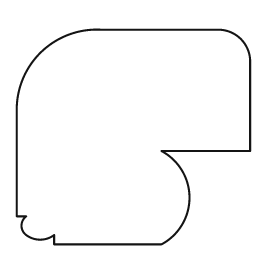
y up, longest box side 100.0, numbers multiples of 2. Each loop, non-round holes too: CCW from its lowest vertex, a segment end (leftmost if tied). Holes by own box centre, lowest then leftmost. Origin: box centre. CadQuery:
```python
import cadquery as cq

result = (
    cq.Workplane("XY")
    .moveTo(-34.0, -46.0)
    .lineTo(12.0, -46.0)
    .threePointArc((24.0, -26.0), (12.0, -6.0))
    .lineTo(50.0, -6.0)
    .lineTo(50.0, 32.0)
    .threePointArc((46.0, 42.0), (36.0, 46.0))
    .lineTo(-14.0, 46.0)
    .threePointArc((-40.0, 36.0), (-50.0, 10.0))
    .lineTo(-50.0, -34.0)
    .lineTo(-46.0, -34.0)
    .threePointArc((-48.0, -38.0), (-46.0, -42.0))
    .threePointArc((-40.0, -44.0), (-34.0, -42.0))
    .close()
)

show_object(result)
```